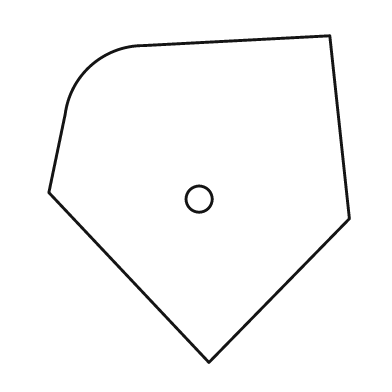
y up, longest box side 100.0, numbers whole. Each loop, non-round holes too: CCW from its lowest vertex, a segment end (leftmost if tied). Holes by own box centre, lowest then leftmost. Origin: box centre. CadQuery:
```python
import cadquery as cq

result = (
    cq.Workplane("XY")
    .moveTo(3.0, -50.0)
    .lineTo(46.0, -6.0)
    .lineTo(40.0, 50.0)
    .lineTo(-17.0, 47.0)
    .threePointArc((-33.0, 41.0), (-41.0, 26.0))
    .lineTo(-46.0, 2.0)
    .close()
    .moveTo(0.0, 0.0)
    .circle(4.0)
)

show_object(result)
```